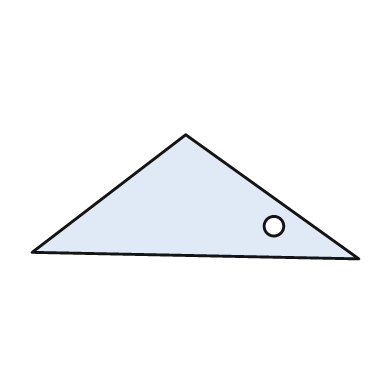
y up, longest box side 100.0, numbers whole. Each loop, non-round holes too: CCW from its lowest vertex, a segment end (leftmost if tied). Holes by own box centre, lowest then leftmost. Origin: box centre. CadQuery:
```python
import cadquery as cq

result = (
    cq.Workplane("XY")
    .moveTo(50.0, -19.0)
    .lineTo(-3.0, 19.0)
    .lineTo(-50.0, -17.0)
    .close()
    .moveTo(24.0, -9.0)
    .circle(3.0)
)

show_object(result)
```